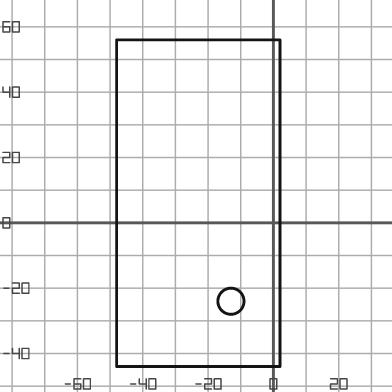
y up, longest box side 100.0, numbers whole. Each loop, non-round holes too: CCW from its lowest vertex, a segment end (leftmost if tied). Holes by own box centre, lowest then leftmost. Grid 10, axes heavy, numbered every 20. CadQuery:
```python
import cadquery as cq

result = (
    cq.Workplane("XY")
    .moveTo(-48.0, -44.0)
    .lineTo(2.0, -44.0)
    .lineTo(2.0, 56.0)
    .lineTo(-48.0, 56.0)
    .close()
    .moveTo(-13.0, -24.0)
    .circle(4.0)
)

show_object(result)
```